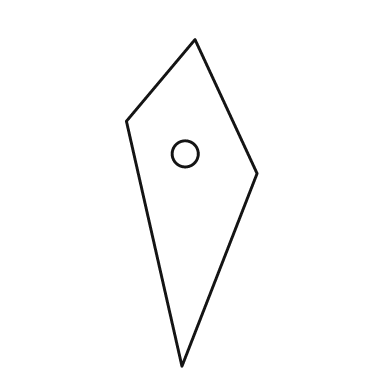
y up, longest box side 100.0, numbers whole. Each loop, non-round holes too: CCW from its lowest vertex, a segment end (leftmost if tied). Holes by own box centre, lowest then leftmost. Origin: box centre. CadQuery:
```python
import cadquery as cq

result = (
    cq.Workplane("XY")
    .moveTo(-3.0, -50.0)
    .lineTo(20.0, 9.0)
    .lineTo(1.0, 50.0)
    .lineTo(-20.0, 25.0)
    .close()
    .moveTo(-2.0, 15.0)
    .circle(4.0)
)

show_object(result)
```